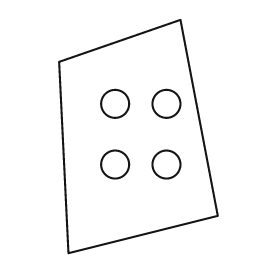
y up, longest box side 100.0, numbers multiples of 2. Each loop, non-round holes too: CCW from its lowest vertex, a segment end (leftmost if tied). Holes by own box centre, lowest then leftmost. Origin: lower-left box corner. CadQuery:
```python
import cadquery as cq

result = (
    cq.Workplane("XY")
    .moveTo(4.0, 0.0)
    .lineTo(68.0, 16.0)
    .lineTo(52.0, 100.0)
    .lineTo(0.0, 82.0)
    .close()
    .moveTo(24.0, 38.0)
    .circle(6.0)
    .moveTo(46.0, 38.0)
    .circle(6.0)
    .moveTo(24.0, 64.0)
    .circle(6.0)
    .moveTo(46.0, 64.0)
    .circle(6.0)
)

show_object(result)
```